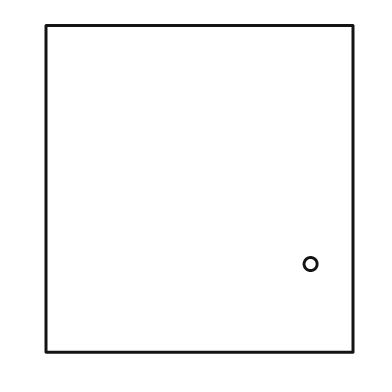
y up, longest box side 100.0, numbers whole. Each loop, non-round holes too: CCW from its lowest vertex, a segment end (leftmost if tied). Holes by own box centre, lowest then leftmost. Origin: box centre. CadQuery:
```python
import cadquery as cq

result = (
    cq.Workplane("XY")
    .moveTo(-47.0, -50.0)
    .lineTo(47.0, -50.0)
    .lineTo(47.0, 50.0)
    .lineTo(-47.0, 50.0)
    .close()
    .moveTo(34.0, -23.0)
    .circle(2.0)
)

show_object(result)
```